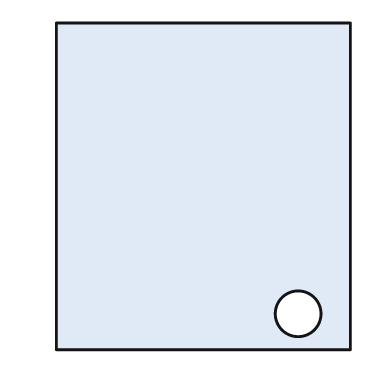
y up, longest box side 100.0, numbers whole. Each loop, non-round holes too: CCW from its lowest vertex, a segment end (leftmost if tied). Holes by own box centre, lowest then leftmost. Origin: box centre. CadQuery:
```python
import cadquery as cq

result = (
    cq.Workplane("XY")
    .moveTo(-45.0, -50.0)
    .lineTo(45.0, -50.0)
    .lineTo(45.0, 50.0)
    .lineTo(-45.0, 50.0)
    .close()
    .moveTo(29.0, -39.0)
    .circle(7.0)
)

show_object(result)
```